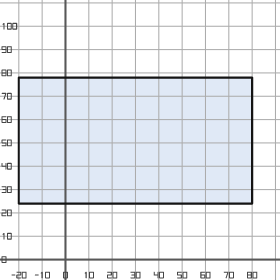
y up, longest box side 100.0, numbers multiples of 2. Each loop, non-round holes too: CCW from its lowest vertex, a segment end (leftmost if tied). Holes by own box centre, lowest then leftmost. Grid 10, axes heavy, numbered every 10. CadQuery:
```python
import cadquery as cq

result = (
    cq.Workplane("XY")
    .moveTo(-20.0, 24.0)
    .lineTo(80.0, 24.0)
    .lineTo(80.0, 78.0)
    .lineTo(-20.0, 78.0)
    .close()
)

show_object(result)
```